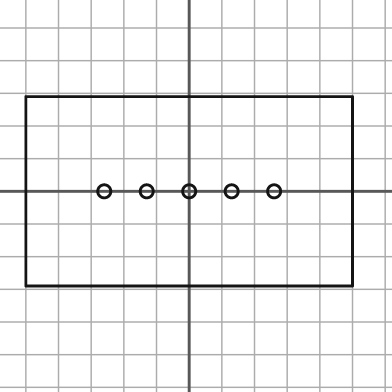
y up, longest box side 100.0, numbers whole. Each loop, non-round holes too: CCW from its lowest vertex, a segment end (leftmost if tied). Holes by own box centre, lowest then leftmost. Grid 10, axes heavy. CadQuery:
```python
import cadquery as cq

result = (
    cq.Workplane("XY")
    .moveTo(-50.0, -29.0)
    .lineTo(50.0, -29.0)
    .lineTo(50.0, 29.0)
    .lineTo(-50.0, 29.0)
    .close()
    .moveTo(-26.0, 0.0)
    .circle(2.0)
    .moveTo(-13.0, 0.0)
    .circle(2.0)
    .moveTo(0.0, 0.0)
    .circle(2.0)
    .moveTo(13.0, 0.0)
    .circle(2.0)
    .moveTo(26.0, 0.0)
    .circle(2.0)
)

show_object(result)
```